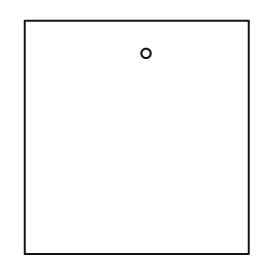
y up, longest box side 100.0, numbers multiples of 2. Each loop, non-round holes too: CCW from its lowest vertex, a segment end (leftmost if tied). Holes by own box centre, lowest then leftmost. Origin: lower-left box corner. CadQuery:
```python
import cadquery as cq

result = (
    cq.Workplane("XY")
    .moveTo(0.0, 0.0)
    .lineTo(96.0, 0.0)
    .lineTo(96.0, 100.0)
    .lineTo(0.0, 100.0)
    .close()
    .moveTo(52.0, 86.0)
    .circle(2.0)
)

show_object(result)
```